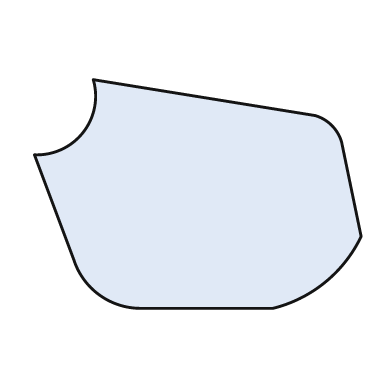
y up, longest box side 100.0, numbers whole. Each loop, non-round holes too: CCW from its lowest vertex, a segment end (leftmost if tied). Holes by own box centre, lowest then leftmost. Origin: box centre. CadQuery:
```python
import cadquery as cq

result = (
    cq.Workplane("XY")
    .moveTo(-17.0, -35.0)
    .lineTo(23.0, -35.0)
    .threePointArc((39.0, -27.0), (50.0, -13.0))
    .lineTo(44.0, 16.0)
    .threePointArc((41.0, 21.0), (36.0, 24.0))
    .lineTo(-32.0, 35.0)
    .threePointArc((-35.0, 19.0), (-50.0, 12.0))
    .lineTo(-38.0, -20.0)
    .threePointArc((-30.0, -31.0), (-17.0, -35.0))
    .close()
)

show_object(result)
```